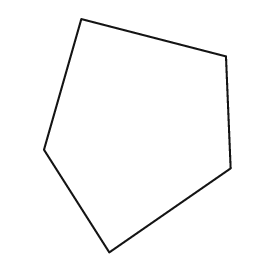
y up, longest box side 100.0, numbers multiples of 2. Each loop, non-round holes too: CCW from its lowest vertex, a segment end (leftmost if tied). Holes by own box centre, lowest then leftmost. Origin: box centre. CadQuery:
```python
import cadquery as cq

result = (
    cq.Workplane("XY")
    .moveTo(-12.0, -50.0)
    .lineTo(40.0, -14.0)
    .lineTo(38.0, 34.0)
    .lineTo(-24.0, 50.0)
    .lineTo(-40.0, -6.0)
    .close()
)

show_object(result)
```